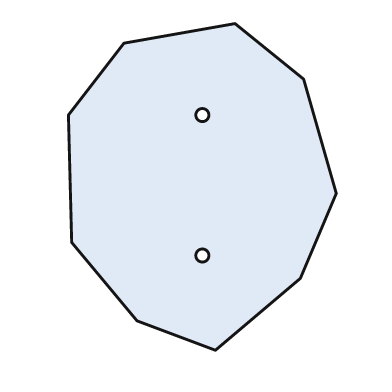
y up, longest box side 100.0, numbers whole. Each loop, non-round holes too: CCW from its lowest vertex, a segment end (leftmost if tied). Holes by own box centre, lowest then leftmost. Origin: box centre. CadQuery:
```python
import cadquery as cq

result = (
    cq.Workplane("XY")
    .moveTo(4.0, -50.0)
    .lineTo(30.0, -28.0)
    .lineTo(41.0, -2.0)
    .lineTo(31.0, 33.0)
    .lineTo(10.0, 50.0)
    .lineTo(-24.0, 44.0)
    .lineTo(-41.0, 22.0)
    .lineTo(-40.0, -17.0)
    .lineTo(-20.0, -41.0)
    .close()
    .moveTo(0.0, -21.0)
    .circle(2.0)
    .moveTo(0.0, 22.0)
    .circle(2.0)
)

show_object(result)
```